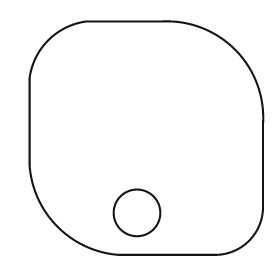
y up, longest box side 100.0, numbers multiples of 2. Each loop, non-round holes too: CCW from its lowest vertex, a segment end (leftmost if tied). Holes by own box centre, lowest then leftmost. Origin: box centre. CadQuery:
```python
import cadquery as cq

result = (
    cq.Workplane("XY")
    .moveTo(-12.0, -50.0)
    .lineTo(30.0, -50.0)
    .threePointArc((44.0, -44.0), (50.0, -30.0))
    .lineTo(50.0, 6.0)
    .threePointArc((38.0, 38.0), (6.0, 50.0))
    .lineTo(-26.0, 50.0)
    .threePointArc((-42.0, 42.0), (-50.0, 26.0))
    .lineTo(-50.0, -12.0)
    .threePointArc((-38.0, -38.0), (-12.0, -50.0))
    .close()
    .moveTo(-4.0, -32.0)
    .circle(10.0)
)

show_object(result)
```